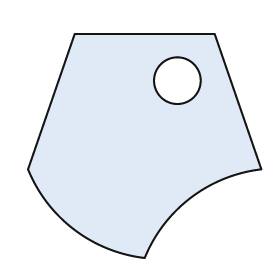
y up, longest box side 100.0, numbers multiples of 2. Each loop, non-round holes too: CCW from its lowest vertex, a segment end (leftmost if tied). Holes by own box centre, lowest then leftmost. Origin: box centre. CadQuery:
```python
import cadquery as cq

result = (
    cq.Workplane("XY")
    .moveTo(0.0, -48.0)
    .threePointArc((20.0, -22.0), (50.0, -10.0))
    .lineTo(30.0, 48.0)
    .lineTo(-30.0, 48.0)
    .lineTo(-50.0, -10.0)
    .threePointArc((-30.0, -36.0), (0.0, -48.0))
    .close()
    .moveTo(14.0, 28.0)
    .circle(10.0)
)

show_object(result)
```